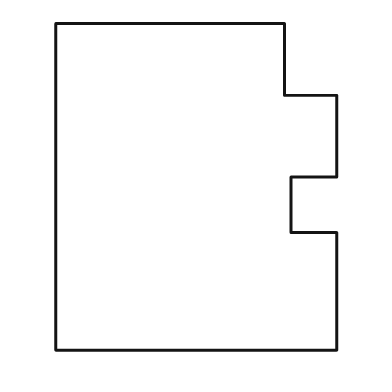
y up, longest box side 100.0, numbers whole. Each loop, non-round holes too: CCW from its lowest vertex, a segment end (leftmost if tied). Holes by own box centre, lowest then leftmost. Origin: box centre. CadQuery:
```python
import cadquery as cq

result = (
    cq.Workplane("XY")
    .moveTo(-43.0, -50.0)
    .lineTo(43.0, -50.0)
    .lineTo(43.0, -14.0)
    .lineTo(29.0, -14.0)
    .lineTo(29.0, 3.0)
    .lineTo(43.0, 3.0)
    .lineTo(43.0, 28.0)
    .lineTo(27.0, 28.0)
    .lineTo(27.0, 50.0)
    .lineTo(-43.0, 50.0)
    .close()
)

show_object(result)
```